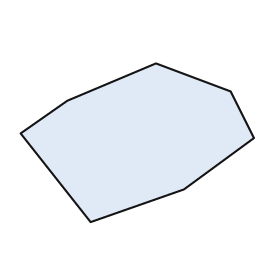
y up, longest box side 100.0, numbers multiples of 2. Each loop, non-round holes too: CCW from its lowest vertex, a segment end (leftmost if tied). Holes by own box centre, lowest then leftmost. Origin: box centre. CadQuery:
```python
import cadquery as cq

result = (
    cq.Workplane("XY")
    .moveTo(-20.0, -34.0)
    .lineTo(20.0, -20.0)
    .lineTo(50.0, 2.0)
    .lineTo(40.0, 22.0)
    .lineTo(8.0, 34.0)
    .lineTo(-30.0, 18.0)
    .lineTo(-50.0, 4.0)
    .close()
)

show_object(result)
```